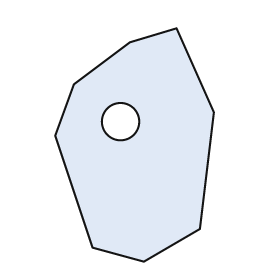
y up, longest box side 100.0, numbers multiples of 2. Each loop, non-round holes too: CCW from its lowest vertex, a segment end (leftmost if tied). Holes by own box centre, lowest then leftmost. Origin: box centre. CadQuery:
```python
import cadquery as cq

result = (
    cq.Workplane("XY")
    .moveTo(4.0, -50.0)
    .lineTo(28.0, -36.0)
    .lineTo(34.0, 14.0)
    .lineTo(18.0, 50.0)
    .lineTo(-2.0, 44.0)
    .lineTo(-26.0, 26.0)
    .lineTo(-34.0, 4.0)
    .lineTo(-18.0, -44.0)
    .close()
    .moveTo(-6.0, 10.0)
    .circle(8.0)
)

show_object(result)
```